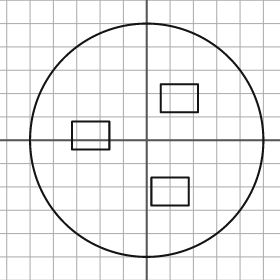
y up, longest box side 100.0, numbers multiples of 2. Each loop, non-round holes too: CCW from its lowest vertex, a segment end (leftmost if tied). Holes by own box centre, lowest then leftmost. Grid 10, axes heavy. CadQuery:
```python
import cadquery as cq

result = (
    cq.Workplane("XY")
    .moveTo(0.0, 0.0)
    .circle(50.0)
    .moveTo(2.0, -28.0)
    .lineTo(18.0, -28.0)
    .lineTo(18.0, -16.0)
    .lineTo(2.0, -16.0)
    .close()
    .moveTo(-32.0, -4.0)
    .lineTo(-16.0, -4.0)
    .lineTo(-16.0, 8.0)
    .lineTo(-32.0, 8.0)
    .close()
    .moveTo(6.0, 12.0)
    .lineTo(22.0, 12.0)
    .lineTo(22.0, 24.0)
    .lineTo(6.0, 24.0)
    .close()
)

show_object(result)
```